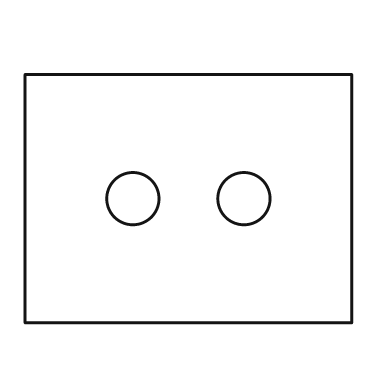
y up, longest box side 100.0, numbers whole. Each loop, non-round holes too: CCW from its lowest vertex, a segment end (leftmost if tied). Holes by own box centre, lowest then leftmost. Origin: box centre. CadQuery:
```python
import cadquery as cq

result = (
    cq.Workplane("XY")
    .moveTo(-50.0, -38.0)
    .lineTo(50.0, -38.0)
    .lineTo(50.0, 38.0)
    .lineTo(-50.0, 38.0)
    .close()
    .moveTo(-17.0, 0.0)
    .circle(8.0)
    .moveTo(17.0, 0.0)
    .circle(8.0)
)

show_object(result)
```